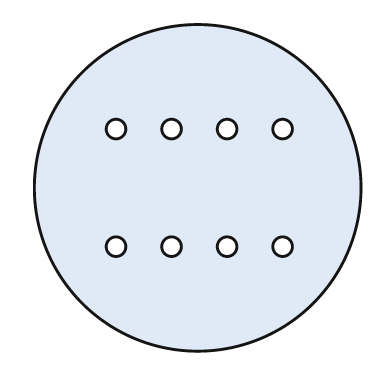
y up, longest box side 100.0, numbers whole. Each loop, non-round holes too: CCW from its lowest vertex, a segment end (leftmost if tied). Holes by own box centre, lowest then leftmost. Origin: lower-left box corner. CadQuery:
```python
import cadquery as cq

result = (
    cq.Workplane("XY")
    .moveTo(50.0, 50.0)
    .circle(50.0)
    .moveTo(25.0, 32.0)
    .circle(3.0)
    .moveTo(42.0, 32.0)
    .circle(3.0)
    .moveTo(59.0, 32.0)
    .circle(3.0)
    .moveTo(76.0, 32.0)
    .circle(3.0)
    .moveTo(25.0, 68.0)
    .circle(3.0)
    .moveTo(42.0, 68.0)
    .circle(3.0)
    .moveTo(59.0, 68.0)
    .circle(3.0)
    .moveTo(76.0, 68.0)
    .circle(3.0)
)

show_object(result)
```